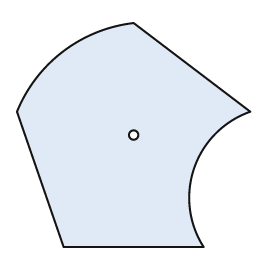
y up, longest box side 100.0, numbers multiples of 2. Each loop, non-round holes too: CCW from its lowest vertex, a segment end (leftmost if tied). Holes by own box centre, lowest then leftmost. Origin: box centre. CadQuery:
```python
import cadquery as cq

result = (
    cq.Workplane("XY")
    .moveTo(-30.0, -48.0)
    .lineTo(30.0, -48.0)
    .threePointArc((26.0, -14.0), (50.0, 10.0))
    .lineTo(0.0, 48.0)
    .threePointArc((-30.0, 36.0), (-50.0, 10.0))
    .close()
    .moveTo(0.0, 0.0)
    .circle(2.0)
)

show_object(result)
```